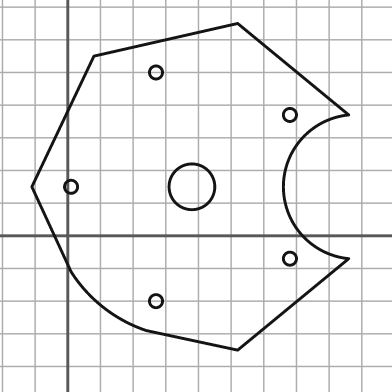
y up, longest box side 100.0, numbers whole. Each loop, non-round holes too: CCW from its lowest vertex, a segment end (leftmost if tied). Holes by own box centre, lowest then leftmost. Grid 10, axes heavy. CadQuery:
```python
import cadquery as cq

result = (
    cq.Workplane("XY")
    .moveTo(52.0, -35.0)
    .lineTo(86.0, -7.0)
    .threePointArc((66.0, 15.0), (86.0, 37.0))
    .lineTo(52.0, 65.0)
    .lineTo(8.0, 55.0)
    .lineTo(-11.0, 15.0)
    .lineTo(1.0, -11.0)
    .threePointArc((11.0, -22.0), (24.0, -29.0))
    .close()
    .moveTo(27.0, -20.0)
    .circle(2.0)
    .moveTo(68.0, -7.0)
    .circle(2.0)
    .moveTo(1.0, 15.0)
    .circle(2.0)
    .moveTo(38.0, 15.0)
    .circle(7.0)
    .moveTo(68.0, 37.0)
    .circle(2.0)
    .moveTo(27.0, 50.0)
    .circle(2.0)
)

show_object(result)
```